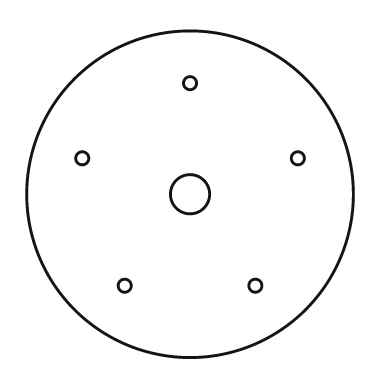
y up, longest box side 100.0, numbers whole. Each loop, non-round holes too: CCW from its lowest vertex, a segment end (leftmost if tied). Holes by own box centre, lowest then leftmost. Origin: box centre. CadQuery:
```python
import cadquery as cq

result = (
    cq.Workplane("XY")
    .moveTo(0.0, 0.0)
    .circle(50.0)
    .moveTo(-20.0, -28.0)
    .circle(2.0)
    .moveTo(20.0, -28.0)
    .circle(2.0)
    .moveTo(0.0, 0.0)
    .circle(6.0)
    .moveTo(-33.0, 11.0)
    .circle(2.0)
    .moveTo(33.0, 11.0)
    .circle(2.0)
    .moveTo(0.0, 34.0)
    .circle(2.0)
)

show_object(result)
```